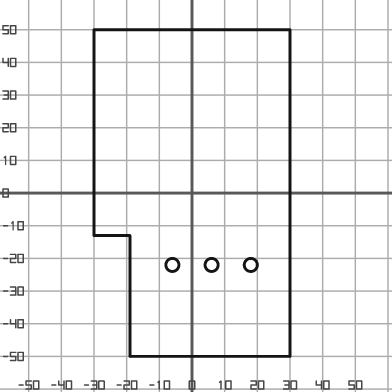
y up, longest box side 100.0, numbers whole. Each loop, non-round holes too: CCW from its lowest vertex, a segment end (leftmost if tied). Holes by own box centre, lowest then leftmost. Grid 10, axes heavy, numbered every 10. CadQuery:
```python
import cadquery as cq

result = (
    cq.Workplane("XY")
    .moveTo(-19.0, -50.0)
    .lineTo(30.0, -50.0)
    .lineTo(30.0, 50.0)
    .lineTo(-30.0, 50.0)
    .lineTo(-30.0, -13.0)
    .lineTo(-19.0, -13.0)
    .close()
    .moveTo(-6.0, -22.0)
    .circle(2.0)
    .moveTo(6.0, -22.0)
    .circle(2.0)
    .moveTo(18.0, -22.0)
    .circle(2.0)
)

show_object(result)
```